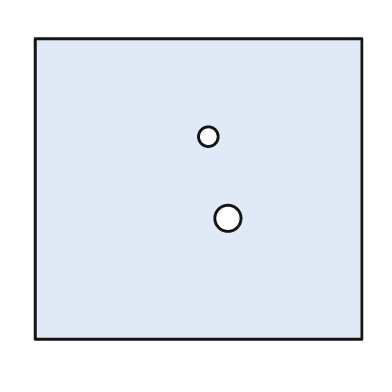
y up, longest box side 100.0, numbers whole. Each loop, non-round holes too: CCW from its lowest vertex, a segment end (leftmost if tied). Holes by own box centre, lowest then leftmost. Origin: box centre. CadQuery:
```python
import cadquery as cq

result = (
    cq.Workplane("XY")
    .moveTo(-50.0, -46.0)
    .lineTo(50.0, -46.0)
    .lineTo(50.0, 46.0)
    .lineTo(-50.0, 46.0)
    .close()
    .moveTo(9.0, -9.0)
    .circle(4.0)
    .moveTo(3.0, 16.0)
    .circle(3.0)
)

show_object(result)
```